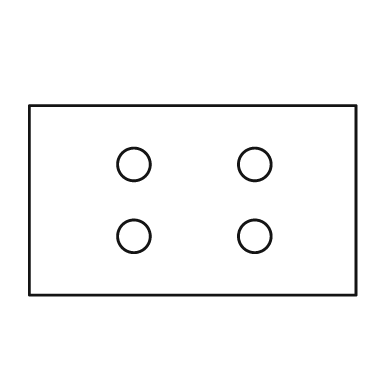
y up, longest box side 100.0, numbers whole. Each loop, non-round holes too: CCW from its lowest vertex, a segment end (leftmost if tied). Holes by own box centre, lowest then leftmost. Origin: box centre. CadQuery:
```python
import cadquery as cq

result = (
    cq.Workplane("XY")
    .moveTo(-50.0, -29.0)
    .lineTo(50.0, -29.0)
    .lineTo(50.0, 29.0)
    .lineTo(-50.0, 29.0)
    .close()
    .moveTo(-18.0, -11.0)
    .circle(5.0)
    .moveTo(19.0, -11.0)
    .circle(5.0)
    .moveTo(-18.0, 11.0)
    .circle(5.0)
    .moveTo(19.0, 11.0)
    .circle(5.0)
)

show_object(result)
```